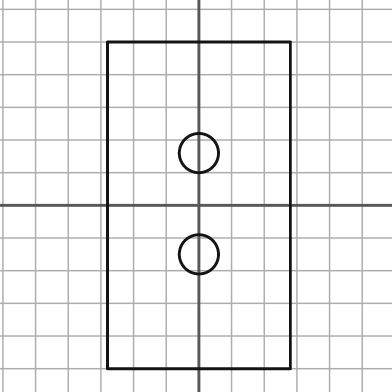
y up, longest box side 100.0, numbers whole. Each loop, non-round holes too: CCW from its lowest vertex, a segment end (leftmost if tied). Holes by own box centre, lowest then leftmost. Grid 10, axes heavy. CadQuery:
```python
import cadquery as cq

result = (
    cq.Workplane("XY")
    .moveTo(-28.0, -50.0)
    .lineTo(28.0, -50.0)
    .lineTo(28.0, 50.0)
    .lineTo(-28.0, 50.0)
    .close()
    .moveTo(0.0, -15.0)
    .circle(6.0)
    .moveTo(0.0, 16.0)
    .circle(6.0)
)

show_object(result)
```